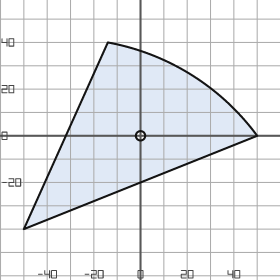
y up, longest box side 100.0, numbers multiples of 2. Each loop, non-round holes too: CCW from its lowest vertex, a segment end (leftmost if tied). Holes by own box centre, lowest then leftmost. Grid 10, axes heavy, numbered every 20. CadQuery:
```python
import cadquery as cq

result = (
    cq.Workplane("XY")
    .moveTo(-50.0, -40.0)
    .lineTo(50.0, 0.0)
    .threePointArc((22.0, 26.0), (-14.0, 40.0))
    .close()
    .moveTo(0.0, 0.0)
    .circle(2.0)
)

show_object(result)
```